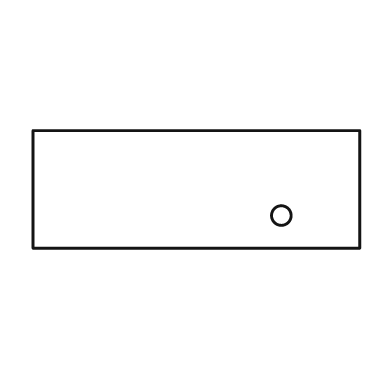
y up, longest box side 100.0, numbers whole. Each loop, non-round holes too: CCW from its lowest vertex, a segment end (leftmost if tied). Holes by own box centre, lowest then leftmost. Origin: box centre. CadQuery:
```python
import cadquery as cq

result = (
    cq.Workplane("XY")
    .moveTo(-50.0, -18.0)
    .lineTo(50.0, -18.0)
    .lineTo(50.0, 18.0)
    .lineTo(-50.0, 18.0)
    .close()
    .moveTo(26.0, -8.0)
    .circle(3.0)
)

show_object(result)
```